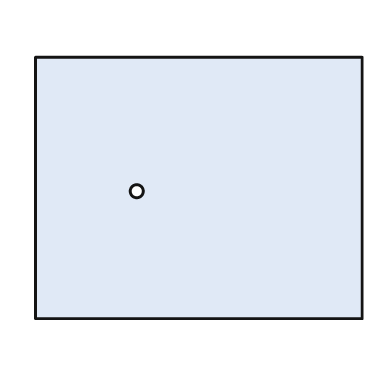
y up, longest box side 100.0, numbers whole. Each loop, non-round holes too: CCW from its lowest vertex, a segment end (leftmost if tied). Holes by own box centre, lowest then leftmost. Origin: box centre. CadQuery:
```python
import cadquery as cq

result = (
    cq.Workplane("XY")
    .moveTo(-50.0, -40.0)
    .lineTo(50.0, -40.0)
    .lineTo(50.0, 40.0)
    .lineTo(-50.0, 40.0)
    .close()
    .moveTo(-19.0, -1.0)
    .circle(2.0)
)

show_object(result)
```